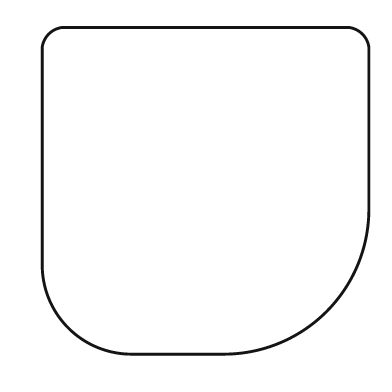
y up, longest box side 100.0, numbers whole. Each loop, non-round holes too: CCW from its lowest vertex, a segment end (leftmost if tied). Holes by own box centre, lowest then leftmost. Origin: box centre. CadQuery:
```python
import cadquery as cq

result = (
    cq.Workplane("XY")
    .moveTo(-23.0, -50.0)
    .lineTo(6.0, -50.0)
    .threePointArc((37.0, -37.0), (50.0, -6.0))
    .lineTo(50.0, 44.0)
    .threePointArc((48.0, 48.0), (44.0, 50.0))
    .lineTo(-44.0, 50.0)
    .threePointArc((-48.0, 48.0), (-50.0, 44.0))
    .lineTo(-50.0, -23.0)
    .threePointArc((-42.0, -42.0), (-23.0, -50.0))
    .close()
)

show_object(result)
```